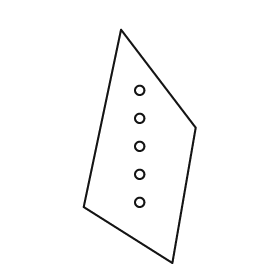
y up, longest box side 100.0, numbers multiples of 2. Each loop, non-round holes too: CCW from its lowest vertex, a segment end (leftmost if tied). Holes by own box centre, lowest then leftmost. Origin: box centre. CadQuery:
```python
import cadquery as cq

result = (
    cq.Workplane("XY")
    .moveTo(14.0, -50.0)
    .lineTo(24.0, 8.0)
    .lineTo(-8.0, 50.0)
    .lineTo(-24.0, -26.0)
    .close()
    .moveTo(0.0, -24.0)
    .circle(2.0)
    .moveTo(0.0, -12.0)
    .circle(2.0)
    .moveTo(0.0, 0.0)
    .circle(2.0)
    .moveTo(0.0, 12.0)
    .circle(2.0)
    .moveTo(0.0, 24.0)
    .circle(2.0)
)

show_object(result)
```